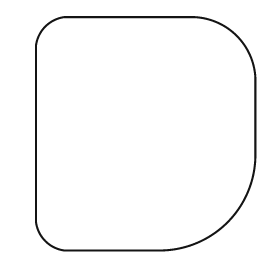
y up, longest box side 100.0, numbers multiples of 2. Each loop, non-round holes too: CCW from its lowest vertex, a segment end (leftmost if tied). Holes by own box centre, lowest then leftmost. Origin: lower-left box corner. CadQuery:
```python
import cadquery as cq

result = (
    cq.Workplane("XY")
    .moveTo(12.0, 0.0)
    .lineTo(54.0, 0.0)
    .threePointArc((82.0, 12.0), (94.0, 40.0))
    .lineTo(94.0, 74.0)
    .threePointArc((86.0, 92.0), (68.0, 100.0))
    .lineTo(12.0, 100.0)
    .threePointArc((4.0, 96.0), (0.0, 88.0))
    .lineTo(0.0, 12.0)
    .threePointArc((4.0, 4.0), (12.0, 0.0))
    .close()
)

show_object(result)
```